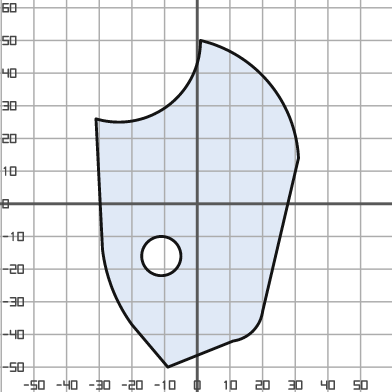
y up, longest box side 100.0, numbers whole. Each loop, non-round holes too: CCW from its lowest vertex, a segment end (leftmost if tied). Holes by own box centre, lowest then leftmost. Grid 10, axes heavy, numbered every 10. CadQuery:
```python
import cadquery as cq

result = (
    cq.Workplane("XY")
    .moveTo(-9.0, -50.0)
    .lineTo(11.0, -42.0)
    .threePointArc((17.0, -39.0), (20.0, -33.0))
    .lineTo(31.0, 14.0)
    .threePointArc((22.0, 37.0), (1.0, 50.0))
    .threePointArc((-9.0, 30.0), (-31.0, 26.0))
    .lineTo(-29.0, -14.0)
    .threePointArc((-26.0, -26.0), (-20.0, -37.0))
    .close()
    .moveTo(-11.0, -16.0)
    .circle(6.0)
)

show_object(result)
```